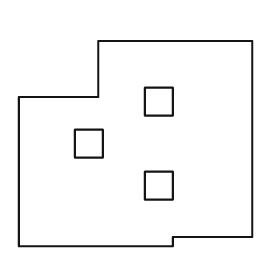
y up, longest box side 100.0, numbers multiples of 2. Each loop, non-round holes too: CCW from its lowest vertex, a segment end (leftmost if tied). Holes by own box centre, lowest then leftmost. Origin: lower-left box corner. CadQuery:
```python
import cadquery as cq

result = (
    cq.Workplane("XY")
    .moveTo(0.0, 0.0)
    .lineTo(66.0, 0.0)
    .lineTo(66.0, 4.0)
    .lineTo(100.0, 4.0)
    .lineTo(100.0, 88.0)
    .lineTo(34.0, 88.0)
    .lineTo(34.0, 64.0)
    .lineTo(0.0, 64.0)
    .close()
    .moveTo(54.0, 20.0)
    .lineTo(66.0, 20.0)
    .lineTo(66.0, 32.0)
    .lineTo(54.0, 32.0)
    .close()
    .moveTo(24.0, 38.0)
    .lineTo(36.0, 38.0)
    .lineTo(36.0, 50.0)
    .lineTo(24.0, 50.0)
    .close()
    .moveTo(54.0, 56.0)
    .lineTo(66.0, 56.0)
    .lineTo(66.0, 68.0)
    .lineTo(54.0, 68.0)
    .close()
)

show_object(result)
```